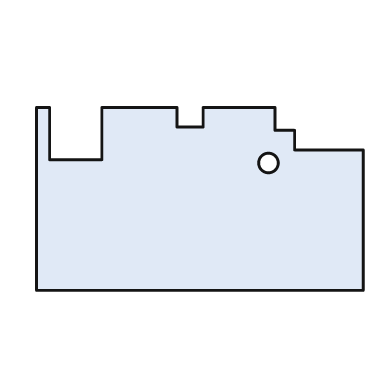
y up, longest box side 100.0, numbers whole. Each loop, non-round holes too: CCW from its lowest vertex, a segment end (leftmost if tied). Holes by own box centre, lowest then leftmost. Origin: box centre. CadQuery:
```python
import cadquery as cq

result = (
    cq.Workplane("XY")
    .moveTo(-50.0, -28.0)
    .lineTo(50.0, -28.0)
    .lineTo(50.0, 15.0)
    .lineTo(29.0, 15.0)
    .lineTo(29.0, 21.0)
    .lineTo(23.0, 21.0)
    .lineTo(23.0, 28.0)
    .lineTo(1.0, 28.0)
    .lineTo(1.0, 22.0)
    .lineTo(-7.0, 22.0)
    .lineTo(-7.0, 28.0)
    .lineTo(-30.0, 28.0)
    .lineTo(-30.0, 12.0)
    .lineTo(-46.0, 12.0)
    .lineTo(-46.0, 28.0)
    .lineTo(-50.0, 28.0)
    .close()
    .moveTo(21.0, 11.0)
    .circle(3.0)
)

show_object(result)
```